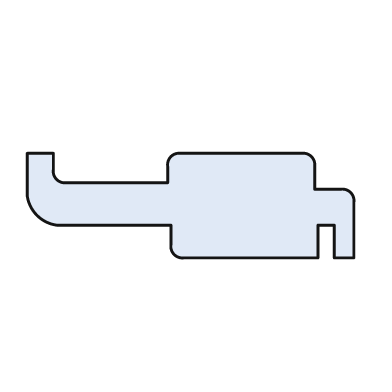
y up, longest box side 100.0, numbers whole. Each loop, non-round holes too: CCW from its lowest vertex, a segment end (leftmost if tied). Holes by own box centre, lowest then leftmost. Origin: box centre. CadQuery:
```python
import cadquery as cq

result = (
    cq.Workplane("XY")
    .moveTo(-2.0, -16.0)
    .lineTo(39.0, -16.0)
    .lineTo(39.0, -6.0)
    .lineTo(44.0, -6.0)
    .lineTo(44.0, -16.0)
    .lineTo(50.0, -16.0)
    .lineTo(50.0, 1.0)
    .threePointArc((49.0, 4.0), (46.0, 5.0))
    .lineTo(38.0, 5.0)
    .lineTo(38.0, 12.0)
    .threePointArc((37.0, 15.0), (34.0, 16.0))
    .lineTo(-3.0, 16.0)
    .threePointArc((-6.0, 15.0), (-7.0, 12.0))
    .lineTo(-7.0, 7.0)
    .lineTo(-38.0, 7.0)
    .threePointArc((-41.0, 8.0), (-42.0, 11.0))
    .lineTo(-42.0, 16.0)
    .lineTo(-50.0, 16.0)
    .lineTo(-50.0, 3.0)
    .threePointArc((-47.0, -3.0), (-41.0, -6.0))
    .lineTo(-6.0, -6.0)
    .lineTo(-6.0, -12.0)
    .threePointArc((-5.0, -15.0), (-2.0, -16.0))
    .close()
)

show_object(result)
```